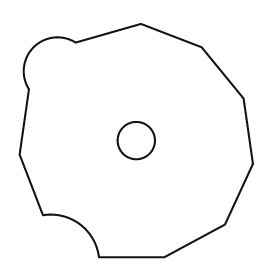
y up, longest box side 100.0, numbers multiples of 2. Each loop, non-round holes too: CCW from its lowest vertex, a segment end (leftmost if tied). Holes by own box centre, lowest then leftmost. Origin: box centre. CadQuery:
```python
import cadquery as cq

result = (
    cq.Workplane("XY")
    .moveTo(-16.0, -50.0)
    .lineTo(12.0, -50.0)
    .lineTo(38.0, -36.0)
    .lineTo(50.0, -10.0)
    .lineTo(46.0, 18.0)
    .lineTo(28.0, 40.0)
    .lineTo(2.0, 50.0)
    .lineTo(-26.0, 42.0)
    .threePointArc((-44.0, 40.0), (-46.0, 22.0))
    .lineTo(-50.0, -6.0)
    .lineTo(-40.0, -32.0)
    .threePointArc((-24.0, -36.0), (-16.0, -50.0))
    .close()
    .moveTo(0.0, 0.0)
    .circle(8.0)
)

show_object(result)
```